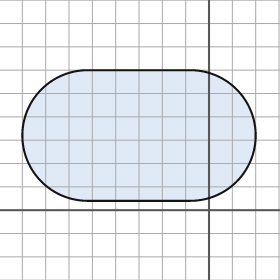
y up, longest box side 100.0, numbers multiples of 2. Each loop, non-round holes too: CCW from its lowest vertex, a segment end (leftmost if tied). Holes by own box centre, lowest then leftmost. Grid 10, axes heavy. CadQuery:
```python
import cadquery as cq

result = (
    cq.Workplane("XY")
    .moveTo(-52.0, 4.0)
    .lineTo(-8.0, 4.0)
    .threePointArc((20.0, 32.0), (-8.0, 60.0))
    .lineTo(-52.0, 60.0)
    .threePointArc((-80.0, 32.0), (-52.0, 4.0))
    .close()
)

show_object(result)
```